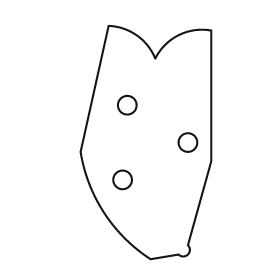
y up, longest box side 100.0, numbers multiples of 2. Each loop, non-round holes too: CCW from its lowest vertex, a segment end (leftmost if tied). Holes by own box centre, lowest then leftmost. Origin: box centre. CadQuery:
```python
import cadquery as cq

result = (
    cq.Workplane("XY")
    .moveTo(2.0, -50.0)
    .lineTo(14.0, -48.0)
    .threePointArc((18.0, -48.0), (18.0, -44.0))
    .lineTo(28.0, -8.0)
    .lineTo(28.0, 48.0)
    .threePointArc((14.0, 46.0), (4.0, 36.0))
    .threePointArc((-4.0, 46.0), (-16.0, 50.0))
    .lineTo(-28.0, -4.0)
    .threePointArc((-18.0, -30.0), (2.0, -50.0))
    .close()
    .moveTo(-10.0, -16.0)
    .circle(4.0)
    .moveTo(18.0, 0.0)
    .circle(4.0)
    .moveTo(-8.0, 16.0)
    .circle(4.0)
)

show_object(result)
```